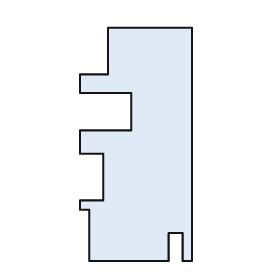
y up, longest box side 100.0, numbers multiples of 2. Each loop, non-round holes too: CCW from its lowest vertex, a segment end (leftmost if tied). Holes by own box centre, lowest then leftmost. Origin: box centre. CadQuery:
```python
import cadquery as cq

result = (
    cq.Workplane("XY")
    .moveTo(-20.0, -50.0)
    .lineTo(14.0, -50.0)
    .lineTo(14.0, -38.0)
    .lineTo(20.0, -38.0)
    .lineTo(20.0, -50.0)
    .lineTo(24.0, -50.0)
    .lineTo(24.0, 50.0)
    .lineTo(-12.0, 50.0)
    .lineTo(-12.0, 30.0)
    .lineTo(-24.0, 30.0)
    .lineTo(-24.0, 22.0)
    .lineTo(-2.0, 22.0)
    .lineTo(-2.0, 6.0)
    .lineTo(-24.0, 6.0)
    .lineTo(-24.0, -4.0)
    .lineTo(-14.0, -4.0)
    .lineTo(-14.0, -24.0)
    .lineTo(-24.0, -24.0)
    .lineTo(-24.0, -28.0)
    .lineTo(-20.0, -28.0)
    .close()
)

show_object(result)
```